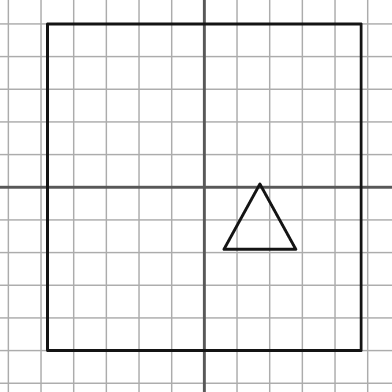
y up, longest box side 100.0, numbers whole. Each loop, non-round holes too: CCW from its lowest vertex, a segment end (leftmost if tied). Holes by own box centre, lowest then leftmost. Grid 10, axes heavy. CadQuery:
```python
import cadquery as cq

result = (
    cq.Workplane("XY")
    .moveTo(-48.0, -50.0)
    .lineTo(48.0, -50.0)
    .lineTo(48.0, 50.0)
    .lineTo(-48.0, 50.0)
    .close()
    .moveTo(6.0, -19.0)
    .lineTo(28.0, -19.0)
    .lineTo(17.0, 1.0)
    .close()
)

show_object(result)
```